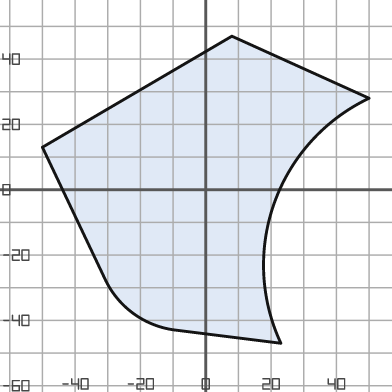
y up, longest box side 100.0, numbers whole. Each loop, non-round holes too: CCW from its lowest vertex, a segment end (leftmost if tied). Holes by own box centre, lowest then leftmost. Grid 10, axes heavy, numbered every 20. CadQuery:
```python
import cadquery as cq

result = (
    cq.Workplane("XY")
    .moveTo(23.0, -47.0)
    .threePointArc((21.0, -4.0), (50.0, 28.0))
    .lineTo(8.0, 47.0)
    .lineTo(-50.0, 13.0)
    .lineTo(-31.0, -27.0)
    .threePointArc((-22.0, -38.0), (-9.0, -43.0))
    .close()
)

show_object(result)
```